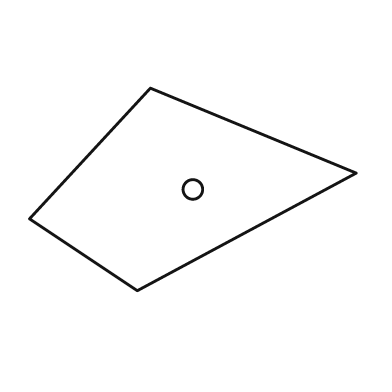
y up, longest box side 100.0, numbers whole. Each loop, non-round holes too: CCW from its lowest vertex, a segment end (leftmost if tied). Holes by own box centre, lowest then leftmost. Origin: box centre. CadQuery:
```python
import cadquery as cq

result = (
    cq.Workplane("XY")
    .moveTo(-17.0, -31.0)
    .lineTo(50.0, 5.0)
    .lineTo(-13.0, 31.0)
    .lineTo(-50.0, -9.0)
    .close()
    .moveTo(0.0, 0.0)
    .circle(3.0)
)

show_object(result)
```